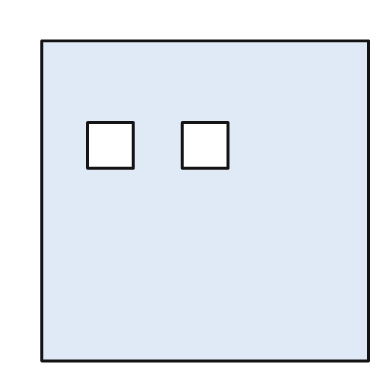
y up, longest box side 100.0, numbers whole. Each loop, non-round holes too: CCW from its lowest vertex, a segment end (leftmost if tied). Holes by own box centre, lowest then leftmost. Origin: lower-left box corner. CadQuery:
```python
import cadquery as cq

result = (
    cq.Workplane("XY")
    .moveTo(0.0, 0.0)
    .lineTo(100.0, 0.0)
    .lineTo(100.0, 98.0)
    .lineTo(0.0, 98.0)
    .close()
    .moveTo(14.0, 59.0)
    .lineTo(28.0, 59.0)
    .lineTo(28.0, 73.0)
    .lineTo(14.0, 73.0)
    .close()
    .moveTo(43.0, 59.0)
    .lineTo(57.0, 59.0)
    .lineTo(57.0, 73.0)
    .lineTo(43.0, 73.0)
    .close()
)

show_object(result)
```